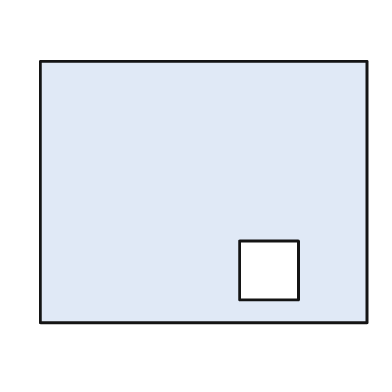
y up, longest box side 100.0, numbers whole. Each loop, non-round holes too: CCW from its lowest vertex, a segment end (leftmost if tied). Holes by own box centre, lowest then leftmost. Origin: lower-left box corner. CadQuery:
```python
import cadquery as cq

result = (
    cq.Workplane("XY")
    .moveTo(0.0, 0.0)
    .lineTo(100.0, 0.0)
    .lineTo(100.0, 80.0)
    .lineTo(0.0, 80.0)
    .close()
    .moveTo(61.0, 7.0)
    .lineTo(79.0, 7.0)
    .lineTo(79.0, 25.0)
    .lineTo(61.0, 25.0)
    .close()
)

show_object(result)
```